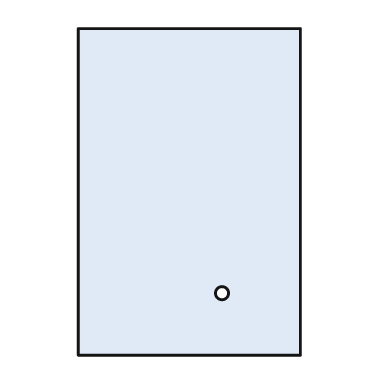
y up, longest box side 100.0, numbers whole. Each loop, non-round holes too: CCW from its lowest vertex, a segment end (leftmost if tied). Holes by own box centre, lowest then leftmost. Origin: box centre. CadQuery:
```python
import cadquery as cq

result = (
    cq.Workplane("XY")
    .moveTo(-34.0, -50.0)
    .lineTo(34.0, -50.0)
    .lineTo(34.0, 50.0)
    .lineTo(-34.0, 50.0)
    .close()
    .moveTo(10.0, -31.0)
    .circle(2.0)
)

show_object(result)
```